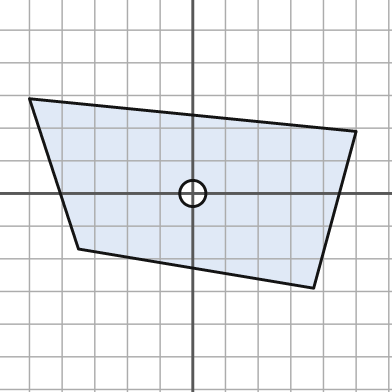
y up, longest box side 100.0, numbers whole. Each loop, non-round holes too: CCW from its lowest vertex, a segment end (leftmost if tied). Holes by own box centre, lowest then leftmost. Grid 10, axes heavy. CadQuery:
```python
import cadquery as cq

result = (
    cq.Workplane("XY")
    .moveTo(37.0, -29.0)
    .lineTo(50.0, 19.0)
    .lineTo(-50.0, 29.0)
    .lineTo(-35.0, -17.0)
    .close()
    .moveTo(0.0, 0.0)
    .circle(4.0)
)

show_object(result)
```